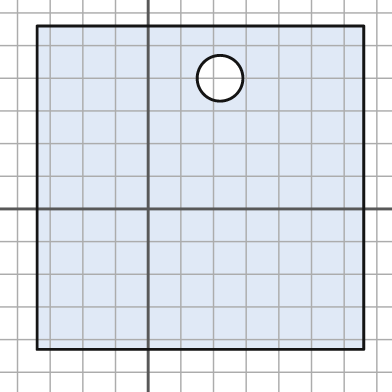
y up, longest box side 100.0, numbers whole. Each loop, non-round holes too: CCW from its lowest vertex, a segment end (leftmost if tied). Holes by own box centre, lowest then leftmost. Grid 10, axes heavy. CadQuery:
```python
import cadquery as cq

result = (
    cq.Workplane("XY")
    .moveTo(-34.0, -43.0)
    .lineTo(66.0, -43.0)
    .lineTo(66.0, 56.0)
    .lineTo(-34.0, 56.0)
    .close()
    .moveTo(22.0, 40.0)
    .circle(7.0)
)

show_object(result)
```